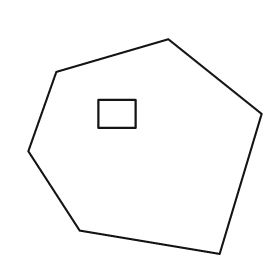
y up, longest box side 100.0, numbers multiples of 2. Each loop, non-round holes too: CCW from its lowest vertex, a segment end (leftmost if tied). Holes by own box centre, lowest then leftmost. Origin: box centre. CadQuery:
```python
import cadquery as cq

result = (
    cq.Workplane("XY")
    .moveTo(32.0, -46.0)
    .lineTo(50.0, 14.0)
    .lineTo(10.0, 46.0)
    .lineTo(-38.0, 32.0)
    .lineTo(-50.0, -2.0)
    .lineTo(-28.0, -36.0)
    .close()
    .moveTo(-20.0, 8.0)
    .lineTo(-4.0, 8.0)
    .lineTo(-4.0, 20.0)
    .lineTo(-20.0, 20.0)
    .close()
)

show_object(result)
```